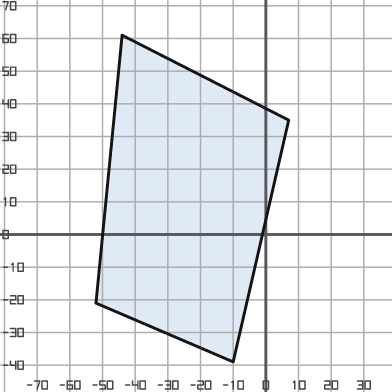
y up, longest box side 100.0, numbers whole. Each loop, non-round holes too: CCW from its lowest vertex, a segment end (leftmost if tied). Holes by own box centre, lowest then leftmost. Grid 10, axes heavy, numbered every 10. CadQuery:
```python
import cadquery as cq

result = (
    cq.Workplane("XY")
    .moveTo(-10.0, -39.0)
    .lineTo(7.0, 35.0)
    .lineTo(-44.0, 61.0)
    .lineTo(-52.0, -21.0)
    .close()
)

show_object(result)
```